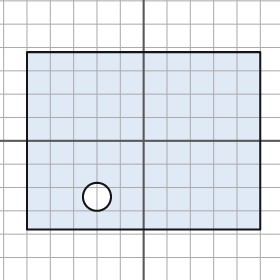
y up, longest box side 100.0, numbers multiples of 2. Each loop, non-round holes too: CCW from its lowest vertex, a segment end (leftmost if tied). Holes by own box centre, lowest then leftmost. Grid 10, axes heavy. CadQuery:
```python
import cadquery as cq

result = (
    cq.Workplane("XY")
    .moveTo(-50.0, -38.0)
    .lineTo(50.0, -38.0)
    .lineTo(50.0, 38.0)
    .lineTo(-50.0, 38.0)
    .close()
    .moveTo(-20.0, -24.0)
    .circle(6.0)
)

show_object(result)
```